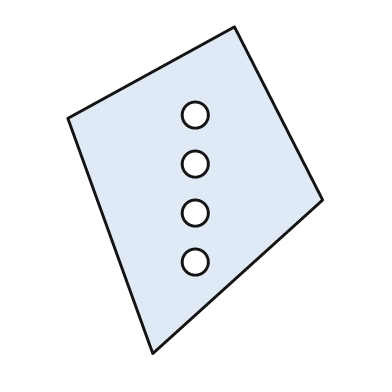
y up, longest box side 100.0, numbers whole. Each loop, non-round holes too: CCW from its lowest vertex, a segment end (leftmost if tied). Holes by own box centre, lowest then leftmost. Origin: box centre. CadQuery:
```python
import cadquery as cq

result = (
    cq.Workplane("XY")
    .moveTo(-13.0, -50.0)
    .lineTo(39.0, -3.0)
    .lineTo(12.0, 50.0)
    .lineTo(-39.0, 22.0)
    .close()
    .moveTo(0.0, -22.0)
    .circle(4.0)
    .moveTo(0.0, -7.0)
    .circle(4.0)
    .moveTo(0.0, 8.0)
    .circle(4.0)
    .moveTo(0.0, 23.0)
    .circle(4.0)
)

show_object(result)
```